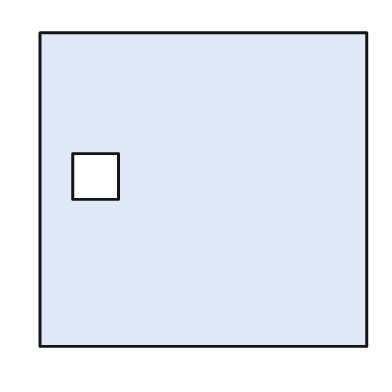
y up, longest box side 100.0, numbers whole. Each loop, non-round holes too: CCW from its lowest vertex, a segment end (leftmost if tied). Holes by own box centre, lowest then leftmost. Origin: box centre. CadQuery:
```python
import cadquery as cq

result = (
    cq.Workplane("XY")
    .moveTo(-50.0, -48.0)
    .lineTo(50.0, -48.0)
    .lineTo(50.0, 48.0)
    .lineTo(-50.0, 48.0)
    .close()
    .moveTo(-40.0, -3.0)
    .lineTo(-26.0, -3.0)
    .lineTo(-26.0, 11.0)
    .lineTo(-40.0, 11.0)
    .close()
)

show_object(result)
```